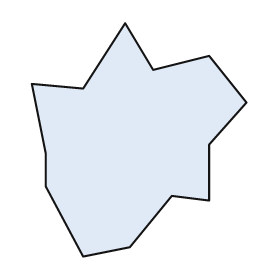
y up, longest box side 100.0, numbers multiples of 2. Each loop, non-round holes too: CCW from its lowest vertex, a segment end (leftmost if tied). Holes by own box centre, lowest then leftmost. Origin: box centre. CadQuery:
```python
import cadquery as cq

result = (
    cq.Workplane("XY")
    .moveTo(-24.0, -50.0)
    .lineTo(-4.0, -46.0)
    .lineTo(14.0, -24.0)
    .lineTo(30.0, -26.0)
    .lineTo(30.0, -2.0)
    .lineTo(46.0, 16.0)
    .lineTo(30.0, 36.0)
    .lineTo(6.0, 30.0)
    .lineTo(-6.0, 50.0)
    .lineTo(-24.0, 22.0)
    .lineTo(-46.0, 24.0)
    .lineTo(-40.0, -6.0)
    .lineTo(-40.0, -20.0)
    .close()
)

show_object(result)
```